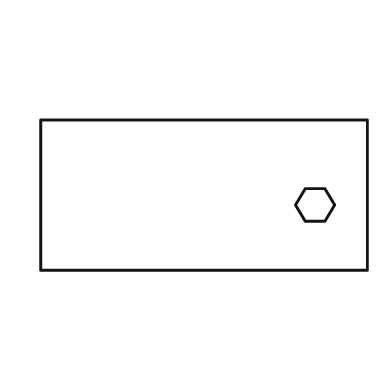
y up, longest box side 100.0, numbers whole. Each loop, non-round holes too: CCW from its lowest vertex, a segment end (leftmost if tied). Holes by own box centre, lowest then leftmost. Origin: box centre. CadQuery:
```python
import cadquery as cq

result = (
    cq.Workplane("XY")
    .moveTo(-50.0, -23.0)
    .lineTo(50.0, -23.0)
    .lineTo(50.0, 23.0)
    .lineTo(-50.0, 23.0)
    .close()
    .moveTo(31.0, -8.0)
    .lineTo(37.0, -8.0)
    .lineTo(40.0, -3.0)
    .lineTo(37.0, 2.0)
    .lineTo(31.0, 2.0)
    .lineTo(28.0, -3.0)
    .close()
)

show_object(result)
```